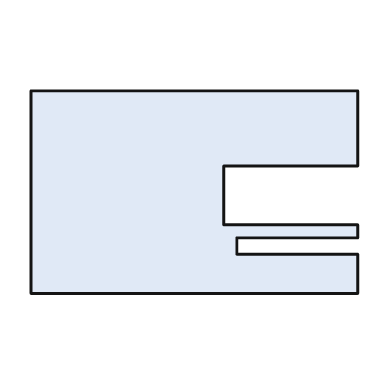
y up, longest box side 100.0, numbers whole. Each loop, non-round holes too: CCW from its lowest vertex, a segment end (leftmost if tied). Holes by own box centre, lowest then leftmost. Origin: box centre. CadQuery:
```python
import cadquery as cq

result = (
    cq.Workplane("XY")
    .moveTo(-50.0, -31.0)
    .lineTo(50.0, -31.0)
    .lineTo(50.0, -19.0)
    .lineTo(13.0, -19.0)
    .lineTo(13.0, -14.0)
    .lineTo(50.0, -14.0)
    .lineTo(50.0, -10.0)
    .lineTo(9.0, -10.0)
    .lineTo(9.0, 8.0)
    .lineTo(50.0, 8.0)
    .lineTo(50.0, 31.0)
    .lineTo(-50.0, 31.0)
    .close()
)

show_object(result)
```